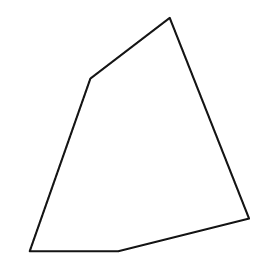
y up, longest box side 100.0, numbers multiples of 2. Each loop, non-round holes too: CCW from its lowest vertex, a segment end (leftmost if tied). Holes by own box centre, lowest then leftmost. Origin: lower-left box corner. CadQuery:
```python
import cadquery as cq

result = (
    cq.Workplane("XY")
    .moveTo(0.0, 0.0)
    .lineTo(38.0, 0.0)
    .lineTo(94.0, 14.0)
    .lineTo(60.0, 100.0)
    .lineTo(26.0, 74.0)
    .close()
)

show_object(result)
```